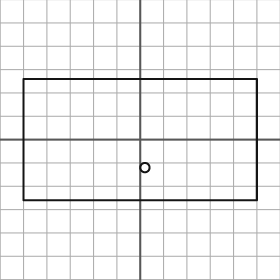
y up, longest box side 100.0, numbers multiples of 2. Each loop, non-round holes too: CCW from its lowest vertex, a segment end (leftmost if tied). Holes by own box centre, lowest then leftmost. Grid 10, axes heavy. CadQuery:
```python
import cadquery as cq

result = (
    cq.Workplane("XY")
    .moveTo(-50.0, -26.0)
    .lineTo(50.0, -26.0)
    .lineTo(50.0, 26.0)
    .lineTo(-50.0, 26.0)
    .close()
    .moveTo(2.0, -12.0)
    .circle(2.0)
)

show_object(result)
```